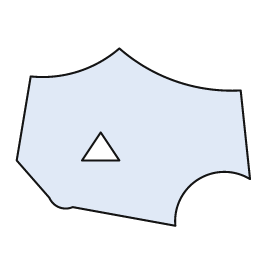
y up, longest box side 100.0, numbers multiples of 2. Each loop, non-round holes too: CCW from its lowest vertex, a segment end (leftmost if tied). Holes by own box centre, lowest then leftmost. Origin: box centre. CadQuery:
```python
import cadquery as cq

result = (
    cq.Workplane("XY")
    .moveTo(18.0, -38.0)
    .threePointArc((28.0, -18.0), (50.0, -18.0))
    .lineTo(46.0, 20.0)
    .threePointArc((18.0, 24.0), (-6.0, 38.0))
    .threePointArc((-24.0, 28.0), (-44.0, 26.0))
    .lineTo(-50.0, -10.0)
    .lineTo(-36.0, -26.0)
    .threePointArc((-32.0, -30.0), (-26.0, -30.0))
    .close()
    .moveTo(-22.0, -10.0)
    .lineTo(-6.0, -10.0)
    .lineTo(-14.0, 2.0)
    .close()
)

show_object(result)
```